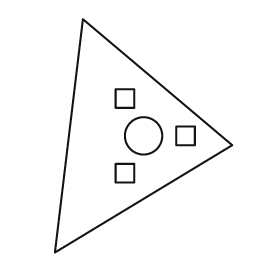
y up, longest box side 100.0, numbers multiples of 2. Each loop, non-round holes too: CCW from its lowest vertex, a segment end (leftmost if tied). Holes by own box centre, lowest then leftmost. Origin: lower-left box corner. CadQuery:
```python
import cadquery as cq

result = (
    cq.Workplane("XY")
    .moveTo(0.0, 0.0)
    .lineTo(76.0, 46.0)
    .lineTo(12.0, 100.0)
    .close()
    .moveTo(26.0, 30.0)
    .lineTo(34.0, 30.0)
    .lineTo(34.0, 38.0)
    .lineTo(26.0, 38.0)
    .close()
    .moveTo(38.0, 50.0)
    .circle(8.0)
    .moveTo(52.0, 46.0)
    .lineTo(60.0, 46.0)
    .lineTo(60.0, 54.0)
    .lineTo(52.0, 54.0)
    .close()
    .moveTo(26.0, 62.0)
    .lineTo(34.0, 62.0)
    .lineTo(34.0, 70.0)
    .lineTo(26.0, 70.0)
    .close()
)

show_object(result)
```